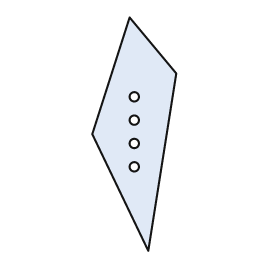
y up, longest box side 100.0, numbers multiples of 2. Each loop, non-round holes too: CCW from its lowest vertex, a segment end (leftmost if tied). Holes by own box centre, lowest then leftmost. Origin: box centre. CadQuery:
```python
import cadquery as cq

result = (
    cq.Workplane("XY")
    .moveTo(6.0, -50.0)
    .lineTo(18.0, 26.0)
    .lineTo(-2.0, 50.0)
    .lineTo(-18.0, 0.0)
    .close()
    .moveTo(0.0, -14.0)
    .circle(2.0)
    .moveTo(0.0, -4.0)
    .circle(2.0)
    .moveTo(0.0, 6.0)
    .circle(2.0)
    .moveTo(0.0, 16.0)
    .circle(2.0)
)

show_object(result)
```